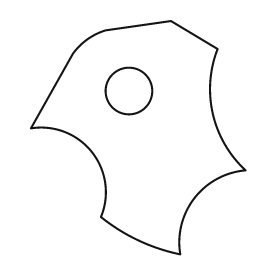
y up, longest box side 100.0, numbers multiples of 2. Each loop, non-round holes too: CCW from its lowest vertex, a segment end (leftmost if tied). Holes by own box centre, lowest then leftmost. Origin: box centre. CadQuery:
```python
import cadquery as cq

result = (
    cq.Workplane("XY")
    .moveTo(18.0, -50.0)
    .threePointArc((24.0, -26.0), (46.0, -14.0))
    .threePointArc((32.0, 10.0), (34.0, 38.0))
    .lineTo(14.0, 50.0)
    .lineTo(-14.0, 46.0)
    .threePointArc((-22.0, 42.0), (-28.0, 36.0))
    .lineTo(-46.0, 4.0)
    .threePointArc((-20.0, -6.0), (-16.0, -34.0))
    .threePointArc((0.0, -44.0), (18.0, -50.0))
    .close()
    .moveTo(-4.0, 20.0)
    .circle(10.0)
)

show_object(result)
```